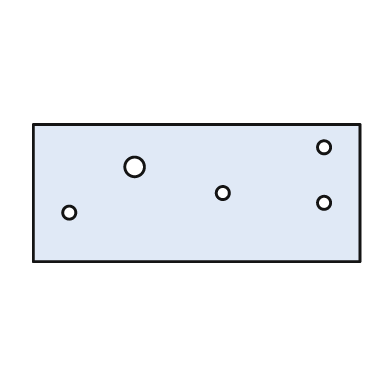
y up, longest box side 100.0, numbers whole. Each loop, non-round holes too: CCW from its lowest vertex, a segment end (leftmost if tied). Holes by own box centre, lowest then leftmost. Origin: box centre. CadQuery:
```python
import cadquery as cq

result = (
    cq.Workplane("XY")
    .moveTo(-50.0, -21.0)
    .lineTo(50.0, -21.0)
    .lineTo(50.0, 21.0)
    .lineTo(-50.0, 21.0)
    .close()
    .moveTo(-39.0, -6.0)
    .circle(2.0)
    .moveTo(39.0, -3.0)
    .circle(2.0)
    .moveTo(8.0, 0.0)
    .circle(2.0)
    .moveTo(-19.0, 8.0)
    .circle(3.0)
    .moveTo(39.0, 14.0)
    .circle(2.0)
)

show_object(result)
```